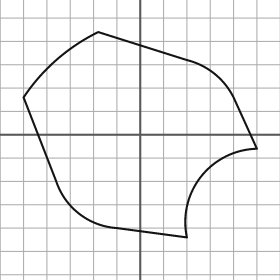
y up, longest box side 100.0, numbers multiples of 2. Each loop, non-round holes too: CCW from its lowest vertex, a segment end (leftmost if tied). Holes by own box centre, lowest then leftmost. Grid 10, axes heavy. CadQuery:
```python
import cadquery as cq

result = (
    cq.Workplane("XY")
    .moveTo(20.0, -44.0)
    .threePointArc((26.0, -18.0), (50.0, -6.0))
    .lineTo(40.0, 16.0)
    .threePointArc((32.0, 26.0), (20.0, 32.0))
    .lineTo(-18.0, 44.0)
    .threePointArc((-36.0, 32.0), (-50.0, 16.0))
    .lineTo(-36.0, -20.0)
    .threePointArc((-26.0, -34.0), (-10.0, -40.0))
    .close()
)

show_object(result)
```